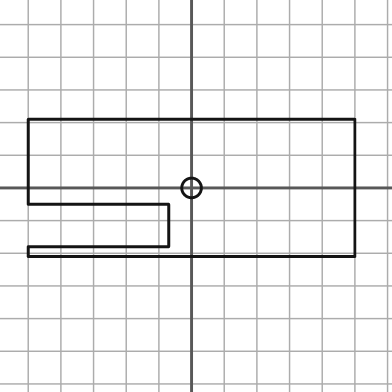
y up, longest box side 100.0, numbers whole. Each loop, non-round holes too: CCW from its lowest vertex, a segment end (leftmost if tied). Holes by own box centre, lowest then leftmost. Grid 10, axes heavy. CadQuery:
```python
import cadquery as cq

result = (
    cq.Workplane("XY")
    .moveTo(-50.0, -21.0)
    .lineTo(50.0, -21.0)
    .lineTo(50.0, 21.0)
    .lineTo(-50.0, 21.0)
    .lineTo(-50.0, -5.0)
    .lineTo(-7.0, -5.0)
    .lineTo(-7.0, -18.0)
    .lineTo(-50.0, -18.0)
    .close()
    .moveTo(0.0, 0.0)
    .circle(3.0)
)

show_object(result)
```